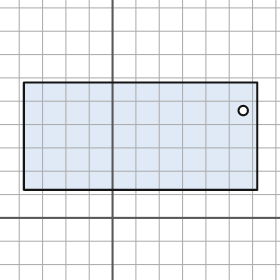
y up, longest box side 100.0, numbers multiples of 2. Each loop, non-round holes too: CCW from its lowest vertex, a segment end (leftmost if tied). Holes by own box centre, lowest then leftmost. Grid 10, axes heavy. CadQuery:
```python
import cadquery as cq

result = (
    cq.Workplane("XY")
    .moveTo(-38.0, 12.0)
    .lineTo(62.0, 12.0)
    .lineTo(62.0, 58.0)
    .lineTo(-38.0, 58.0)
    .close()
    .moveTo(56.0, 46.0)
    .circle(2.0)
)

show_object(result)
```